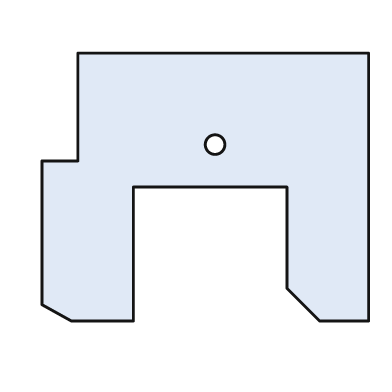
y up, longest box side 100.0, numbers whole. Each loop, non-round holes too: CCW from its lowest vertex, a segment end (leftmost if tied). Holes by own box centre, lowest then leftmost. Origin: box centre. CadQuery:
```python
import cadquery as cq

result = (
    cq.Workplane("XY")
    .moveTo(-41.0, -41.0)
    .lineTo(-22.0, -41.0)
    .lineTo(-22.0, 0.0)
    .lineTo(25.0, 0.0)
    .lineTo(25.0, -31.0)
    .lineTo(35.0, -41.0)
    .lineTo(50.0, -41.0)
    .lineTo(50.0, 41.0)
    .lineTo(-39.0, 41.0)
    .lineTo(-39.0, 8.0)
    .lineTo(-50.0, 8.0)
    .lineTo(-50.0, -36.0)
    .close()
    .moveTo(3.0, 13.0)
    .circle(3.0)
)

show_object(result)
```